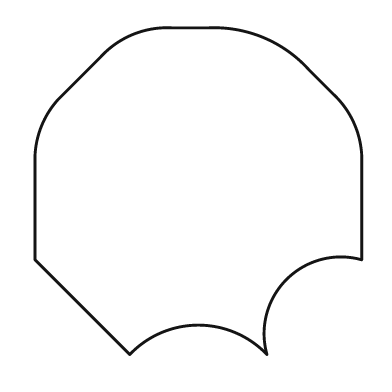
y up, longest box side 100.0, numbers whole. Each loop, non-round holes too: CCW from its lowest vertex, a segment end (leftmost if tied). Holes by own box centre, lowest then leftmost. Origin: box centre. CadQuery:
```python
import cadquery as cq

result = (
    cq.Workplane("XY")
    .moveTo(-21.0, -50.0)
    .threePointArc((0.0, -41.0), (21.0, -50.0))
    .threePointArc((27.0, -27.0), (50.0, -21.0))
    .lineTo(50.0, 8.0)
    .threePointArc((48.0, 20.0), (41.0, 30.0))
    .lineTo(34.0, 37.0)
    .threePointArc((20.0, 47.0), (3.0, 50.0))
    .lineTo(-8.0, 50.0)
    .threePointArc((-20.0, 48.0), (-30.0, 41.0))
    .lineTo(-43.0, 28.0)
    .threePointArc((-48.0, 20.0), (-50.0, 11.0))
    .lineTo(-50.0, -21.0)
    .close()
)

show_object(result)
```